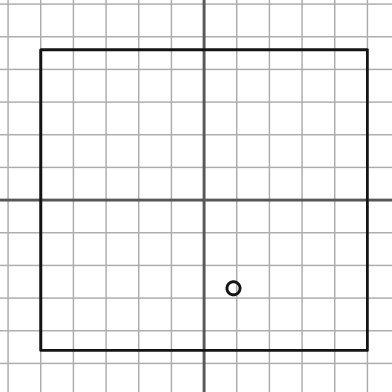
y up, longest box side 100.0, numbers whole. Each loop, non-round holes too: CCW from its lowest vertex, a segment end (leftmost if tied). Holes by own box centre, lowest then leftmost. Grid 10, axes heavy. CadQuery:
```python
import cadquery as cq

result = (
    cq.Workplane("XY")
    .moveTo(-50.0, -46.0)
    .lineTo(50.0, -46.0)
    .lineTo(50.0, 46.0)
    .lineTo(-50.0, 46.0)
    .close()
    .moveTo(9.0, -27.0)
    .circle(2.0)
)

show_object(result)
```